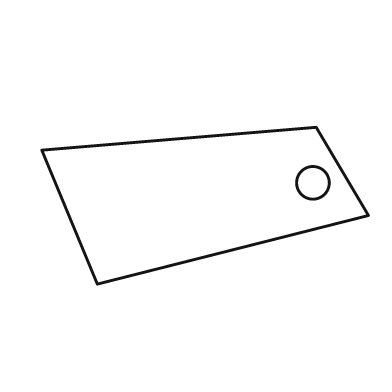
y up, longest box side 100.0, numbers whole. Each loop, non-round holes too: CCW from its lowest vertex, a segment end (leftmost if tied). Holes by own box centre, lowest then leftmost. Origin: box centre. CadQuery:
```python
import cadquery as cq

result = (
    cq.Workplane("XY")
    .moveTo(-33.0, -24.0)
    .lineTo(50.0, -3.0)
    .lineTo(34.0, 24.0)
    .lineTo(-50.0, 17.0)
    .close()
    .moveTo(33.0, 7.0)
    .circle(5.0)
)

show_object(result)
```